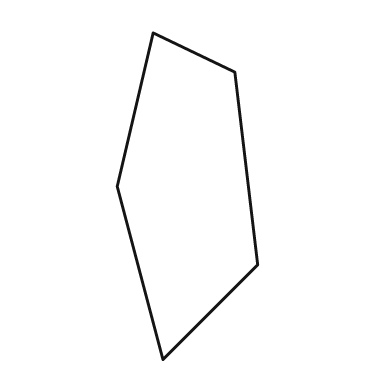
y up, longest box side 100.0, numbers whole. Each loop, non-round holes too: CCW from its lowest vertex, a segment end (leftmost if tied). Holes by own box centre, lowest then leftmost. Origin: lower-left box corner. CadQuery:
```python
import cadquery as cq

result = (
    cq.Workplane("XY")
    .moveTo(14.0, 0.0)
    .lineTo(43.0, 29.0)
    .lineTo(36.0, 88.0)
    .lineTo(11.0, 100.0)
    .lineTo(0.0, 53.0)
    .close()
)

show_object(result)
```